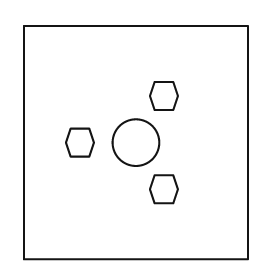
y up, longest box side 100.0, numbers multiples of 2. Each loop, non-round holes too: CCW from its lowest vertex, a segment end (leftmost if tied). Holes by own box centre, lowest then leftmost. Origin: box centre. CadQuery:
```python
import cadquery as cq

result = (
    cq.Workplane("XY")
    .moveTo(-48.0, -50.0)
    .lineTo(48.0, -50.0)
    .lineTo(48.0, 50.0)
    .lineTo(-48.0, 50.0)
    .close()
    .moveTo(8.0, -26.0)
    .lineTo(16.0, -26.0)
    .lineTo(18.0, -20.0)
    .lineTo(16.0, -14.0)
    .lineTo(8.0, -14.0)
    .lineTo(6.0, -20.0)
    .close()
    .moveTo(-28.0, -6.0)
    .lineTo(-20.0, -6.0)
    .lineTo(-18.0, 0.0)
    .lineTo(-20.0, 6.0)
    .lineTo(-28.0, 6.0)
    .lineTo(-30.0, 0.0)
    .close()
    .moveTo(0.0, 0.0)
    .circle(10.0)
    .moveTo(8.0, 14.0)
    .lineTo(16.0, 14.0)
    .lineTo(18.0, 20.0)
    .lineTo(16.0, 26.0)
    .lineTo(8.0, 26.0)
    .lineTo(6.0, 20.0)
    .close()
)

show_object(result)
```